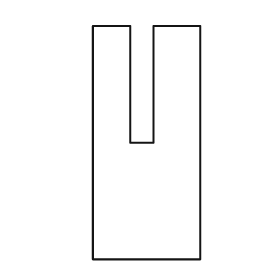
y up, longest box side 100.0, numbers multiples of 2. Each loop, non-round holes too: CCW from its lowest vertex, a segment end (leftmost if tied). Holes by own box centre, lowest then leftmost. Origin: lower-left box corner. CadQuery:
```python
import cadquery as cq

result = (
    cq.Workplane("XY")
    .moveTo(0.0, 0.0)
    .lineTo(46.0, 0.0)
    .lineTo(46.0, 100.0)
    .lineTo(26.0, 100.0)
    .lineTo(26.0, 50.0)
    .lineTo(16.0, 50.0)
    .lineTo(16.0, 100.0)
    .lineTo(0.0, 100.0)
    .close()
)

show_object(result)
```